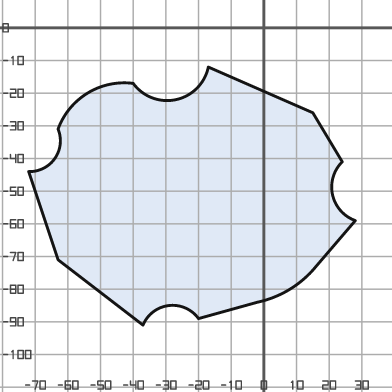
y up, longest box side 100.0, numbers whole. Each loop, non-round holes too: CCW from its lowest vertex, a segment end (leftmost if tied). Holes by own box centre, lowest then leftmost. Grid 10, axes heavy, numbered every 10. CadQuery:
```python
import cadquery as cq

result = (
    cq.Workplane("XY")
    .moveTo(-37.0, -91.0)
    .threePointArc((-29.0, -85.0), (-20.0, -89.0))
    .lineTo(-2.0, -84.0)
    .threePointArc((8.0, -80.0), (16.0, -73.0))
    .lineTo(28.0, -59.0)
    .threePointArc((21.0, -51.0), (24.0, -41.0))
    .lineTo(15.0, -26.0)
    .lineTo(-17.0, -12.0)
    .threePointArc((-27.0, -22.0), (-40.0, -17.0))
    .threePointArc((-54.0, -20.0), (-63.0, -31.0))
    .threePointArc((-64.0, -40.0), (-72.0, -44.0))
    .lineTo(-63.0, -71.0)
    .close()
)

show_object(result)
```